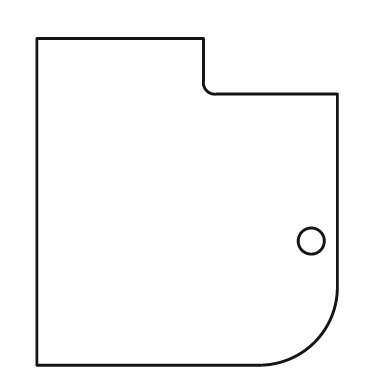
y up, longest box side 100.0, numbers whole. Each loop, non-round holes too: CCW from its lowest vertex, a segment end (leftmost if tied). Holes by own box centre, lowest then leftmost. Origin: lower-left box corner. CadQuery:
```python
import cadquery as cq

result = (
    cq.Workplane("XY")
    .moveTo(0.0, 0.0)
    .lineTo(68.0, 0.0)
    .threePointArc((85.0, 7.0), (92.0, 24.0))
    .lineTo(92.0, 83.0)
    .lineTo(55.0, 83.0)
    .threePointArc((52.0, 84.0), (51.0, 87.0))
    .lineTo(51.0, 100.0)
    .lineTo(0.0, 100.0)
    .close()
    .moveTo(84.0, 38.0)
    .circle(4.0)
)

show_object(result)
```